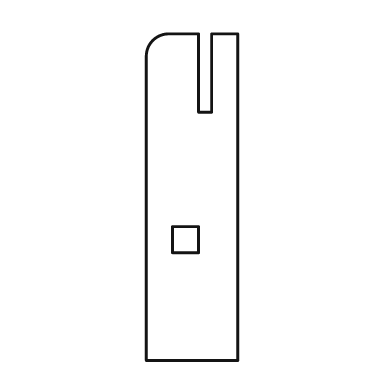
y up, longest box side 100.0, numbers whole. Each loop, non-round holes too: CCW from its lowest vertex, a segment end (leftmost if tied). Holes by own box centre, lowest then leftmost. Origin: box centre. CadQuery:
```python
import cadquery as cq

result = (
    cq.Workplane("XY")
    .moveTo(-14.0, -50.0)
    .lineTo(14.0, -50.0)
    .lineTo(14.0, 50.0)
    .lineTo(6.0, 50.0)
    .lineTo(6.0, 26.0)
    .lineTo(2.0, 26.0)
    .lineTo(2.0, 50.0)
    .lineTo(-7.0, 50.0)
    .threePointArc((-12.0, 48.0), (-14.0, 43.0))
    .close()
    .moveTo(-6.0, -17.0)
    .lineTo(2.0, -17.0)
    .lineTo(2.0, -9.0)
    .lineTo(-6.0, -9.0)
    .close()
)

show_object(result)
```